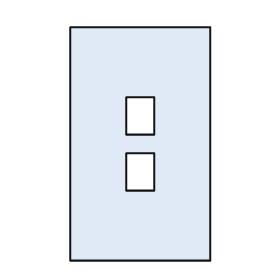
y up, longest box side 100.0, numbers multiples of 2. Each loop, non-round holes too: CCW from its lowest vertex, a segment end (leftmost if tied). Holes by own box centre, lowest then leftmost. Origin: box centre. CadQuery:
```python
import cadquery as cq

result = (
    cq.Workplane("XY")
    .moveTo(-30.0, -50.0)
    .lineTo(30.0, -50.0)
    .lineTo(30.0, 50.0)
    .lineTo(-30.0, 50.0)
    .close()
    .moveTo(-6.0, -20.0)
    .lineTo(6.0, -20.0)
    .lineTo(6.0, -4.0)
    .lineTo(-6.0, -4.0)
    .close()
    .moveTo(-6.0, 4.0)
    .lineTo(6.0, 4.0)
    .lineTo(6.0, 20.0)
    .lineTo(-6.0, 20.0)
    .close()
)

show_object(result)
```